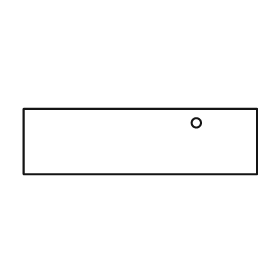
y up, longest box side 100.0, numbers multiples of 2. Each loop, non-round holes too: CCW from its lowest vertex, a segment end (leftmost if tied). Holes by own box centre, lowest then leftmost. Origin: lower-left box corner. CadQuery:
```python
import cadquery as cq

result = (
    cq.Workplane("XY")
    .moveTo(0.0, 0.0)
    .lineTo(100.0, 0.0)
    .lineTo(100.0, 28.0)
    .lineTo(0.0, 28.0)
    .close()
    .moveTo(74.0, 22.0)
    .circle(2.0)
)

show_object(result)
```